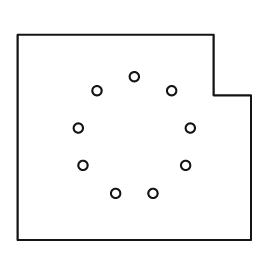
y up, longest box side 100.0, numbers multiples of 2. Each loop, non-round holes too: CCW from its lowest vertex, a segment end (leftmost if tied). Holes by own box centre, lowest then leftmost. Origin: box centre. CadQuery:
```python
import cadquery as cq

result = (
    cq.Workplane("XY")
    .moveTo(-50.0, -44.0)
    .lineTo(50.0, -44.0)
    .lineTo(50.0, 18.0)
    .lineTo(34.0, 18.0)
    .lineTo(34.0, 44.0)
    .lineTo(-50.0, 44.0)
    .close()
    .moveTo(-8.0, -24.0)
    .circle(2.0)
    .moveTo(8.0, -24.0)
    .circle(2.0)
    .moveTo(-22.0, -12.0)
    .circle(2.0)
    .moveTo(22.0, -12.0)
    .circle(2.0)
    .moveTo(-24.0, 4.0)
    .circle(2.0)
    .moveTo(24.0, 4.0)
    .circle(2.0)
    .moveTo(-16.0, 20.0)
    .circle(2.0)
    .moveTo(16.0, 20.0)
    .circle(2.0)
    .moveTo(0.0, 26.0)
    .circle(2.0)
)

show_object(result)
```